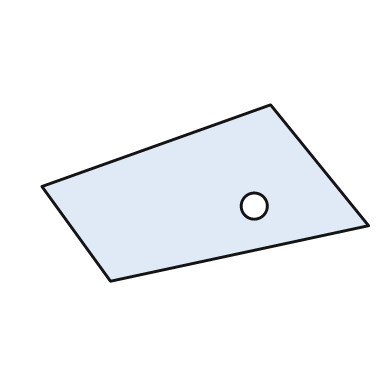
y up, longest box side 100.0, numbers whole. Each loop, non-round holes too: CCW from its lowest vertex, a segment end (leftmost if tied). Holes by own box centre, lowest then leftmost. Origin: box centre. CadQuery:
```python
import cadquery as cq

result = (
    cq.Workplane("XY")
    .moveTo(-29.0, -27.0)
    .lineTo(50.0, -10.0)
    .lineTo(20.0, 27.0)
    .lineTo(-50.0, 2.0)
    .close()
    .moveTo(15.0, -4.0)
    .circle(4.0)
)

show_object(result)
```